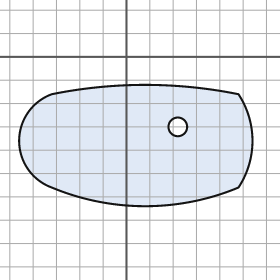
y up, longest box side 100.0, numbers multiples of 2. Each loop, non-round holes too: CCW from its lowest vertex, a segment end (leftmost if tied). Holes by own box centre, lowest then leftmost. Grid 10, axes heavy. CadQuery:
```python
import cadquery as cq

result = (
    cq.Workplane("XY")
    .moveTo(-32.0, -56.0)
    .threePointArc((8.0, -64.0), (48.0, -56.0))
    .threePointArc((54.0, -36.0), (48.0, -16.0))
    .threePointArc((8.0, -12.0), (-32.0, -16.0))
    .threePointArc((-46.0, -36.0), (-32.0, -56.0))
    .close()
    .moveTo(22.0, -30.0)
    .circle(4.0)
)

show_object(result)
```